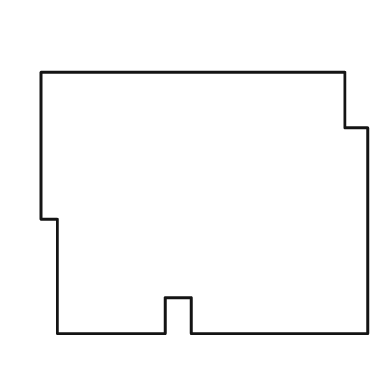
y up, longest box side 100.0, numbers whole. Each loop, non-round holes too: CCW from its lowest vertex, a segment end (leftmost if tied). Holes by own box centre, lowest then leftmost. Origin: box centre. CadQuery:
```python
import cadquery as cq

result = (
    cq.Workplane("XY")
    .moveTo(-45.0, -40.0)
    .lineTo(-12.0, -40.0)
    .lineTo(-12.0, -29.0)
    .lineTo(-4.0, -29.0)
    .lineTo(-4.0, -40.0)
    .lineTo(50.0, -40.0)
    .lineTo(50.0, 23.0)
    .lineTo(43.0, 23.0)
    .lineTo(43.0, 40.0)
    .lineTo(-50.0, 40.0)
    .lineTo(-50.0, -5.0)
    .lineTo(-45.0, -5.0)
    .close()
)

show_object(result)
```